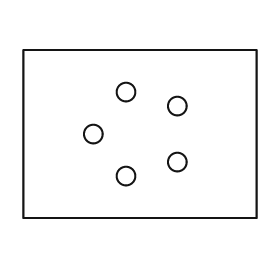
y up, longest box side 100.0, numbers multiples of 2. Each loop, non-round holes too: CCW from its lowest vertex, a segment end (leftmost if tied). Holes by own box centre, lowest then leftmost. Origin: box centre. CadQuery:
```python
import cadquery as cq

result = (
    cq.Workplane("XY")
    .moveTo(-50.0, -36.0)
    .lineTo(50.0, -36.0)
    .lineTo(50.0, 36.0)
    .lineTo(-50.0, 36.0)
    .close()
    .moveTo(-6.0, -18.0)
    .circle(4.0)
    .moveTo(16.0, -12.0)
    .circle(4.0)
    .moveTo(-20.0, 0.0)
    .circle(4.0)
    .moveTo(16.0, 12.0)
    .circle(4.0)
    .moveTo(-6.0, 18.0)
    .circle(4.0)
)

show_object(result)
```